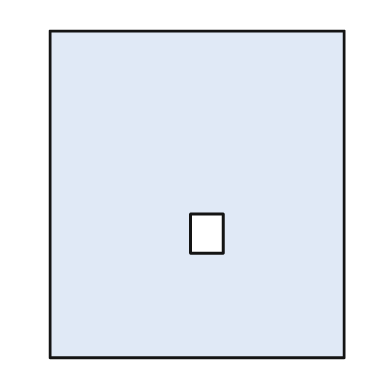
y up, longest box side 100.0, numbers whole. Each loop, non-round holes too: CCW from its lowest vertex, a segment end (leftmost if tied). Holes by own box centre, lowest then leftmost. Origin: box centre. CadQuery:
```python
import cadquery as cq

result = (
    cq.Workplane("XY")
    .moveTo(-45.0, -50.0)
    .lineTo(45.0, -50.0)
    .lineTo(45.0, 50.0)
    .lineTo(-45.0, 50.0)
    .close()
    .moveTo(-2.0, -18.0)
    .lineTo(8.0, -18.0)
    .lineTo(8.0, -6.0)
    .lineTo(-2.0, -6.0)
    .close()
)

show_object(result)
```